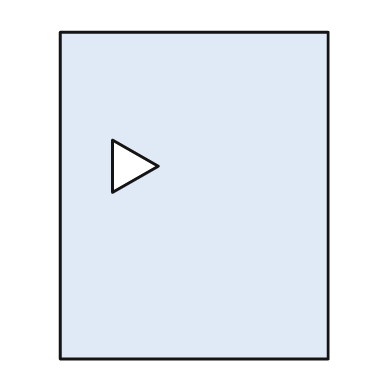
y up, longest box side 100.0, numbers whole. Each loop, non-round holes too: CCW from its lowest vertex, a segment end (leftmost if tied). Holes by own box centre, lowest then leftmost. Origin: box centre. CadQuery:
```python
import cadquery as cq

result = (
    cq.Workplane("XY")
    .moveTo(-41.0, -50.0)
    .lineTo(41.0, -50.0)
    .lineTo(41.0, 50.0)
    .lineTo(-41.0, 50.0)
    .close()
    .moveTo(-25.0, 1.0)
    .lineTo(-11.0, 9.0)
    .lineTo(-25.0, 17.0)
    .close()
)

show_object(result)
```